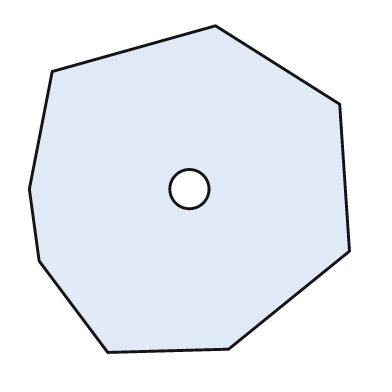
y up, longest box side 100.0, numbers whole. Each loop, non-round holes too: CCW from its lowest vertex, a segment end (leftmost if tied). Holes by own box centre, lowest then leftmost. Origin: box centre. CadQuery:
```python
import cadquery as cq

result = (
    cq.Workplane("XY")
    .moveTo(-25.0, -50.0)
    .lineTo(12.0, -49.0)
    .lineTo(49.0, -19.0)
    .lineTo(46.0, 26.0)
    .lineTo(8.0, 50.0)
    .lineTo(-42.0, 36.0)
    .lineTo(-49.0, 0.0)
    .lineTo(-46.0, -22.0)
    .close()
    .moveTo(0.0, 0.0)
    .circle(6.0)
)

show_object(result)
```